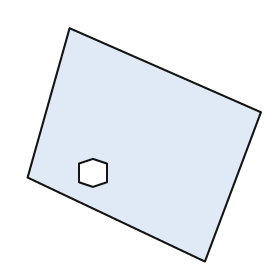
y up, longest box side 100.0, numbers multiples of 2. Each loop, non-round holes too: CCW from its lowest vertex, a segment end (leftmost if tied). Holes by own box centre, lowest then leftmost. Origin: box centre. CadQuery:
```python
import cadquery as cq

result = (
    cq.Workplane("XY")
    .moveTo(26.0, -50.0)
    .lineTo(50.0, 14.0)
    .lineTo(-32.0, 50.0)
    .lineTo(-50.0, -14.0)
    .close()
    .moveTo(-22.0, -18.0)
    .lineTo(-16.0, -16.0)
    .lineTo(-16.0, -8.0)
    .lineTo(-22.0, -6.0)
    .lineTo(-28.0, -8.0)
    .lineTo(-28.0, -16.0)
    .close()
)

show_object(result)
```